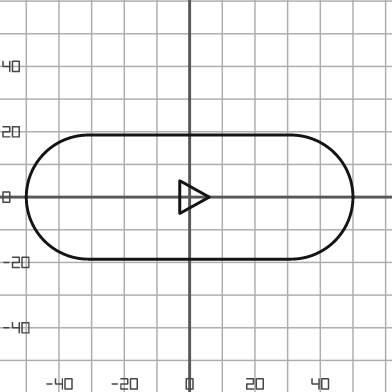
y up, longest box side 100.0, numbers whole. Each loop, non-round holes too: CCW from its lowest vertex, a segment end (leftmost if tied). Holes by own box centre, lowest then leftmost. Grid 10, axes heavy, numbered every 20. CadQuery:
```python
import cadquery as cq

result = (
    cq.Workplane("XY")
    .moveTo(-31.0, -19.0)
    .lineTo(31.0, -19.0)
    .threePointArc((50.0, 0.0), (31.0, 19.0))
    .lineTo(-31.0, 19.0)
    .threePointArc((-50.0, 0.0), (-31.0, -19.0))
    .close()
    .moveTo(-3.0, -5.0)
    .lineTo(6.0, 0.0)
    .lineTo(-3.0, 5.0)
    .close()
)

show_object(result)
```